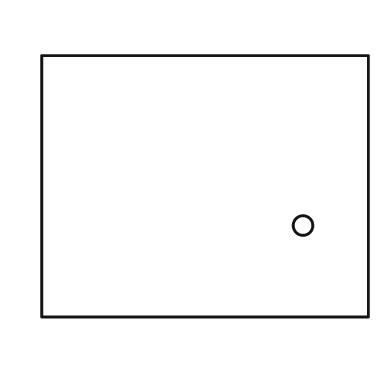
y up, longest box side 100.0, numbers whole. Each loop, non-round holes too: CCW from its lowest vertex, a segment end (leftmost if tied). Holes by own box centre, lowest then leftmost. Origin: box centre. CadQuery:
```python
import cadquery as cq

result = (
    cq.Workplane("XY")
    .moveTo(-50.0, -40.0)
    .lineTo(50.0, -40.0)
    .lineTo(50.0, 40.0)
    .lineTo(-50.0, 40.0)
    .close()
    .moveTo(30.0, -12.0)
    .circle(3.0)
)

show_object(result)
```